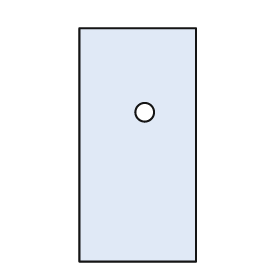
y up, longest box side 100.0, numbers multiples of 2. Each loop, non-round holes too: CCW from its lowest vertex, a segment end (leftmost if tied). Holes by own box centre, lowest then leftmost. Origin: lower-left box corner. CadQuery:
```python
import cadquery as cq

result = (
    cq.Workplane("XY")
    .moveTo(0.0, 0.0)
    .lineTo(50.0, 0.0)
    .lineTo(50.0, 100.0)
    .lineTo(0.0, 100.0)
    .close()
    .moveTo(28.0, 64.0)
    .circle(4.0)
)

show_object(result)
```